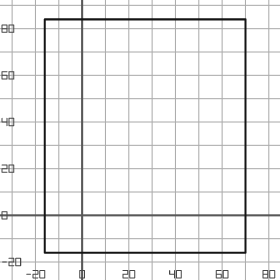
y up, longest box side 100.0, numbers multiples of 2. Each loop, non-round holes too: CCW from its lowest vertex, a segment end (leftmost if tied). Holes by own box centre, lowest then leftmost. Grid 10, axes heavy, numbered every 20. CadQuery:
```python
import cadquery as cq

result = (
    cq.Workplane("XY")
    .moveTo(-16.0, -16.0)
    .lineTo(70.0, -16.0)
    .lineTo(70.0, 84.0)
    .lineTo(-16.0, 84.0)
    .close()
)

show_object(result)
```